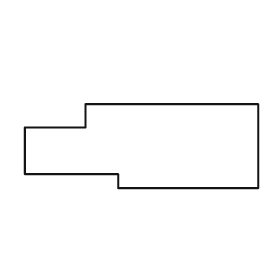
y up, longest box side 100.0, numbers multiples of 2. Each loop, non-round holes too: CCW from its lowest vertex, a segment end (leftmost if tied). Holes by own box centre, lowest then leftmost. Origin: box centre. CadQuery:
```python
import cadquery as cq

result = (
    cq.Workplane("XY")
    .moveTo(-10.0, -18.0)
    .lineTo(50.0, -18.0)
    .lineTo(50.0, 18.0)
    .lineTo(-24.0, 18.0)
    .lineTo(-24.0, 8.0)
    .lineTo(-50.0, 8.0)
    .lineTo(-50.0, -12.0)
    .lineTo(-10.0, -12.0)
    .close()
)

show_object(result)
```